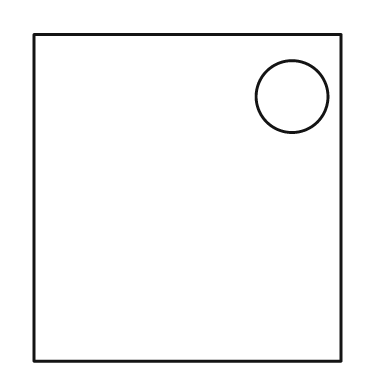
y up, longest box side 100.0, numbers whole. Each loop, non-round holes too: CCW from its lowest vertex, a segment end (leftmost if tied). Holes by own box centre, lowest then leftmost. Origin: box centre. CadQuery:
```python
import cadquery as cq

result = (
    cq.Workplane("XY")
    .moveTo(-47.0, -50.0)
    .lineTo(47.0, -50.0)
    .lineTo(47.0, 50.0)
    .lineTo(-47.0, 50.0)
    .close()
    .moveTo(32.0, 31.0)
    .circle(11.0)
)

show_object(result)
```